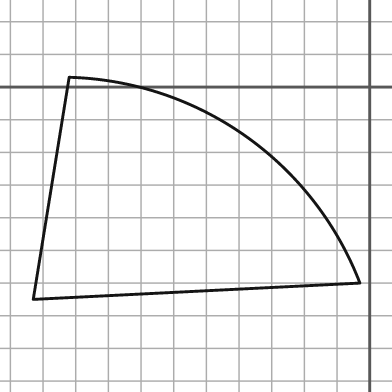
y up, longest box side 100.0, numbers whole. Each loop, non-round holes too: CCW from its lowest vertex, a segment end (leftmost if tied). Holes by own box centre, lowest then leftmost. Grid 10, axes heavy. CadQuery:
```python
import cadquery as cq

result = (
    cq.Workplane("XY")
    .moveTo(-103.0, -65.0)
    .lineTo(-3.0, -60.0)
    .threePointArc((-38.0, -15.0), (-92.0, 3.0))
    .close()
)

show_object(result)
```